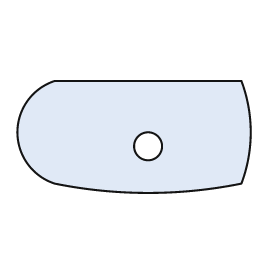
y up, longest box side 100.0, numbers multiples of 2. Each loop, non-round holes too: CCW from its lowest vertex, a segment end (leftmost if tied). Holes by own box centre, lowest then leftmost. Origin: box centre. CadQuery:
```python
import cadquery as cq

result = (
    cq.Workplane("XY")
    .moveTo(-34.0, -20.0)
    .threePointArc((6.0, -24.0), (46.0, -20.0))
    .threePointArc((50.0, 2.0), (46.0, 24.0))
    .lineTo(-34.0, 24.0)
    .threePointArc((-50.0, 2.0), (-34.0, -20.0))
    .close()
    .moveTo(6.0, -4.0)
    .circle(6.0)
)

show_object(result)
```